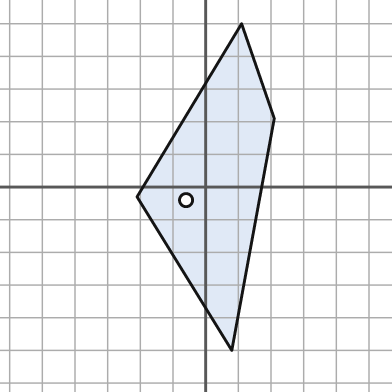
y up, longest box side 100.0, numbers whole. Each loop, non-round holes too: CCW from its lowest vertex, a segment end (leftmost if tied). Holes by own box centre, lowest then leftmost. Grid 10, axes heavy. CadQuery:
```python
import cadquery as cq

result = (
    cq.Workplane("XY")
    .moveTo(8.0, -50.0)
    .lineTo(21.0, 21.0)
    .lineTo(11.0, 50.0)
    .lineTo(-21.0, -3.0)
    .close()
    .moveTo(-6.0, -4.0)
    .circle(2.0)
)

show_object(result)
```